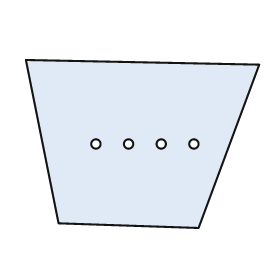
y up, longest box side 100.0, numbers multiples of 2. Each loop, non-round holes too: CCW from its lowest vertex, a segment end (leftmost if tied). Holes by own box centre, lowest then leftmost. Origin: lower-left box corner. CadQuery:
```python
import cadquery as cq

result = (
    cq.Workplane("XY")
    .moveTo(74.0, 0.0)
    .lineTo(100.0, 70.0)
    .lineTo(0.0, 72.0)
    .lineTo(14.0, 2.0)
    .close()
    .moveTo(30.0, 36.0)
    .circle(2.0)
    .moveTo(44.0, 36.0)
    .circle(2.0)
    .moveTo(58.0, 36.0)
    .circle(2.0)
    .moveTo(72.0, 36.0)
    .circle(2.0)
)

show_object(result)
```